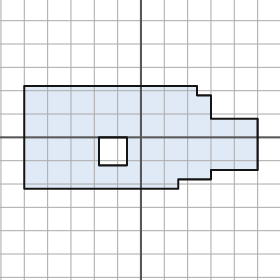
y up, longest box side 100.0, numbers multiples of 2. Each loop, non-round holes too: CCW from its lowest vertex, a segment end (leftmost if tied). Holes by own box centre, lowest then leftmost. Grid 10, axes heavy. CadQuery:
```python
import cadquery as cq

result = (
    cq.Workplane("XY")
    .moveTo(-50.0, -22.0)
    .lineTo(16.0, -22.0)
    .lineTo(16.0, -18.0)
    .lineTo(30.0, -18.0)
    .lineTo(30.0, -14.0)
    .lineTo(50.0, -14.0)
    .lineTo(50.0, 8.0)
    .lineTo(30.0, 8.0)
    .lineTo(30.0, 18.0)
    .lineTo(24.0, 18.0)
    .lineTo(24.0, 22.0)
    .lineTo(-50.0, 22.0)
    .close()
    .moveTo(-18.0, -12.0)
    .lineTo(-6.0, -12.0)
    .lineTo(-6.0, 0.0)
    .lineTo(-18.0, 0.0)
    .close()
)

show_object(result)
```